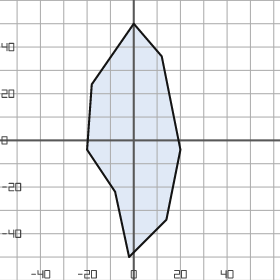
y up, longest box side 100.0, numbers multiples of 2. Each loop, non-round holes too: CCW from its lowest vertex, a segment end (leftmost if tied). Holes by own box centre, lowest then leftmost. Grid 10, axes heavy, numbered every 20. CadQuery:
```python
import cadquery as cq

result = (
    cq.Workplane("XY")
    .moveTo(-2.0, -50.0)
    .lineTo(14.0, -34.0)
    .lineTo(20.0, -4.0)
    .lineTo(12.0, 36.0)
    .lineTo(0.0, 50.0)
    .lineTo(-18.0, 24.0)
    .lineTo(-20.0, -4.0)
    .lineTo(-8.0, -22.0)
    .close()
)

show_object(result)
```